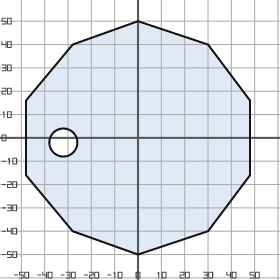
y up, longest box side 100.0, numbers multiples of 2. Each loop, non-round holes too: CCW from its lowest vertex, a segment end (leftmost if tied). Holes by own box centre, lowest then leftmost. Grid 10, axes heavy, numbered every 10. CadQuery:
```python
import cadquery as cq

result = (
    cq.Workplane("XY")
    .moveTo(0.0, -50.0)
    .lineTo(30.0, -40.0)
    .lineTo(48.0, -16.0)
    .lineTo(48.0, 16.0)
    .lineTo(30.0, 40.0)
    .lineTo(0.0, 50.0)
    .lineTo(-28.0, 40.0)
    .lineTo(-48.0, 16.0)
    .lineTo(-48.0, -16.0)
    .lineTo(-28.0, -40.0)
    .close()
    .moveTo(-32.0, -2.0)
    .circle(6.0)
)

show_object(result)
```